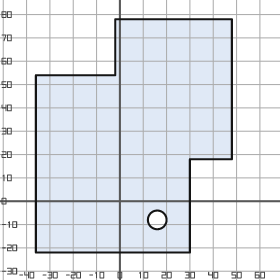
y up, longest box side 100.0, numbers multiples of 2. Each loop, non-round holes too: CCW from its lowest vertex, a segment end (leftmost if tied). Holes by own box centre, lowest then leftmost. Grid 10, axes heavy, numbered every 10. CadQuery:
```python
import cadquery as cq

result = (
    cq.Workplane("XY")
    .moveTo(-36.0, -22.0)
    .lineTo(30.0, -22.0)
    .lineTo(30.0, 18.0)
    .lineTo(48.0, 18.0)
    .lineTo(48.0, 78.0)
    .lineTo(-2.0, 78.0)
    .lineTo(-2.0, 54.0)
    .lineTo(-36.0, 54.0)
    .close()
    .moveTo(16.0, -8.0)
    .circle(4.0)
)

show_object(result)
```